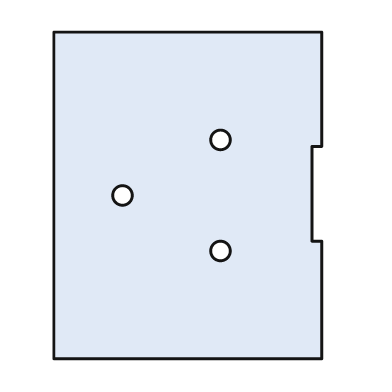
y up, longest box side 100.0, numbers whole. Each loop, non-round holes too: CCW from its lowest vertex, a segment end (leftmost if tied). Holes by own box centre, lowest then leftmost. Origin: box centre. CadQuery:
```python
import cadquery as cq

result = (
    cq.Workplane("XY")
    .moveTo(-41.0, -50.0)
    .lineTo(41.0, -50.0)
    .lineTo(41.0, -14.0)
    .lineTo(38.0, -14.0)
    .lineTo(38.0, 15.0)
    .lineTo(41.0, 15.0)
    .lineTo(41.0, 50.0)
    .lineTo(-41.0, 50.0)
    .close()
    .moveTo(10.0, -17.0)
    .circle(3.0)
    .moveTo(-20.0, 0.0)
    .circle(3.0)
    .moveTo(10.0, 17.0)
    .circle(3.0)
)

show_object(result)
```